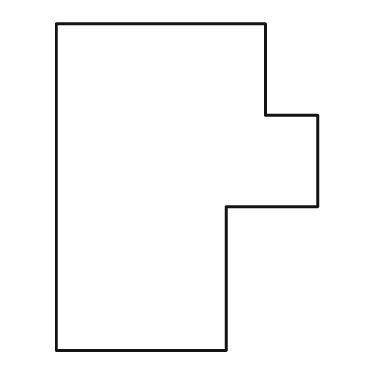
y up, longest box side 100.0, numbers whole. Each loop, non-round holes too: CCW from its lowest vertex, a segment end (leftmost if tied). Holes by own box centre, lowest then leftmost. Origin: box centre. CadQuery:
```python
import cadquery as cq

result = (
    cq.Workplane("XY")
    .moveTo(-40.0, -50.0)
    .lineTo(12.0, -50.0)
    .lineTo(12.0, -6.0)
    .lineTo(40.0, -6.0)
    .lineTo(40.0, 22.0)
    .lineTo(24.0, 22.0)
    .lineTo(24.0, 50.0)
    .lineTo(-40.0, 50.0)
    .close()
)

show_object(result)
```